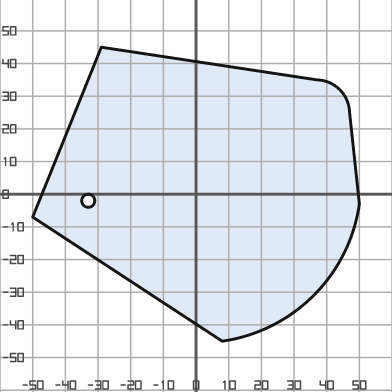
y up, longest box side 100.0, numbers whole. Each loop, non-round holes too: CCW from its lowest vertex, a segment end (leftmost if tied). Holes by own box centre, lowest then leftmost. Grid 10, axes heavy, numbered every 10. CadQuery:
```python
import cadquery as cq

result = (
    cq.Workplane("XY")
    .moveTo(8.0, -45.0)
    .threePointArc((36.0, -31.0), (50.0, -3.0))
    .lineTo(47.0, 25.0)
    .threePointArc((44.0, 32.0), (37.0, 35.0))
    .lineTo(-29.0, 45.0)
    .lineTo(-50.0, -7.0)
    .close()
    .moveTo(-33.0, -2.0)
    .circle(2.0)
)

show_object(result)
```